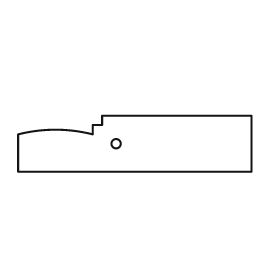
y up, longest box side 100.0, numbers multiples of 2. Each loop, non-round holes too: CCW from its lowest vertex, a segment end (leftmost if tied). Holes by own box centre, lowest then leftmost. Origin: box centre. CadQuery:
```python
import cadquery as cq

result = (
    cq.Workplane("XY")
    .moveTo(-50.0, -12.0)
    .lineTo(50.0, -12.0)
    .lineTo(50.0, 12.0)
    .lineTo(-14.0, 12.0)
    .lineTo(-14.0, 8.0)
    .lineTo(-18.0, 8.0)
    .lineTo(-18.0, 4.0)
    .threePointArc((-34.0, 6.0), (-50.0, 4.0))
    .close()
    .moveTo(-8.0, 0.0)
    .circle(2.0)
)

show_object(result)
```